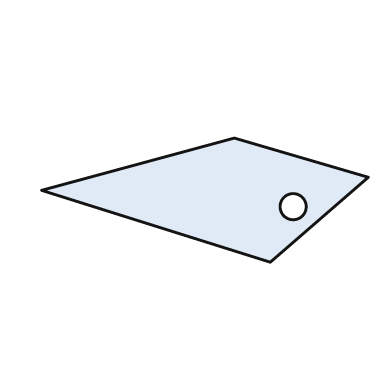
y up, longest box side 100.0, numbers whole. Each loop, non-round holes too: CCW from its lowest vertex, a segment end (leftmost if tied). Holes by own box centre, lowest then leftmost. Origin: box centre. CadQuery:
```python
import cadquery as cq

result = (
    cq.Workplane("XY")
    .moveTo(20.0, -19.0)
    .lineTo(50.0, 7.0)
    .lineTo(9.0, 19.0)
    .lineTo(-50.0, 3.0)
    .close()
    .moveTo(27.0, -2.0)
    .circle(4.0)
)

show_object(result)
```